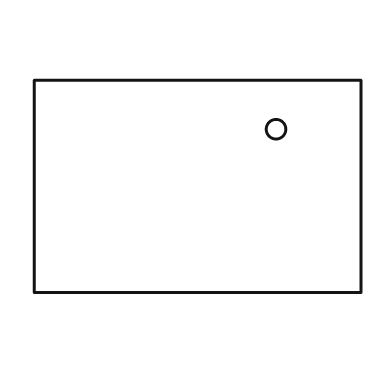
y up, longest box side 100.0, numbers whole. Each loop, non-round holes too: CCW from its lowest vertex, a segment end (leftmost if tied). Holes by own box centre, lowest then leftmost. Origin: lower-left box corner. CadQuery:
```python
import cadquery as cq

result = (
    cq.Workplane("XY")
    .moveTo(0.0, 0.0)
    .lineTo(100.0, 0.0)
    .lineTo(100.0, 65.0)
    .lineTo(0.0, 65.0)
    .close()
    .moveTo(74.0, 50.0)
    .circle(3.0)
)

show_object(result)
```